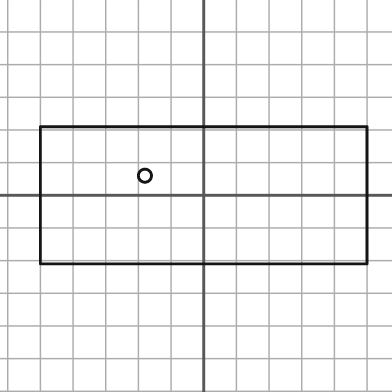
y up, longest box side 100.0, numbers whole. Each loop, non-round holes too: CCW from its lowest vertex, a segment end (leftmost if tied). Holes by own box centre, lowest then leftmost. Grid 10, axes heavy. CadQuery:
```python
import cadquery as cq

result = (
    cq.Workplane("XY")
    .moveTo(-50.0, -21.0)
    .lineTo(50.0, -21.0)
    .lineTo(50.0, 21.0)
    .lineTo(-50.0, 21.0)
    .close()
    .moveTo(-18.0, 6.0)
    .circle(2.0)
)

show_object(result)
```